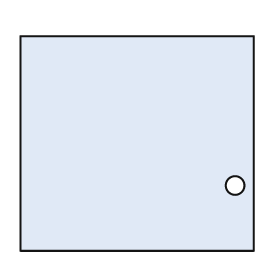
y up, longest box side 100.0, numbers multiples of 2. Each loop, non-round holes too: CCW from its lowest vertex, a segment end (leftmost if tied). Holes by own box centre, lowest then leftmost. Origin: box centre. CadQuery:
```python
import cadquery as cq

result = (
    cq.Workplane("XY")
    .moveTo(-50.0, -46.0)
    .lineTo(50.0, -46.0)
    .lineTo(50.0, 46.0)
    .lineTo(-50.0, 46.0)
    .close()
    .moveTo(42.0, -18.0)
    .circle(4.0)
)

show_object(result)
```